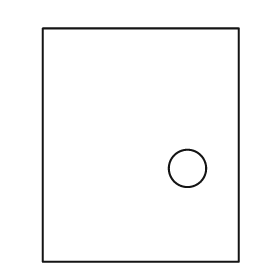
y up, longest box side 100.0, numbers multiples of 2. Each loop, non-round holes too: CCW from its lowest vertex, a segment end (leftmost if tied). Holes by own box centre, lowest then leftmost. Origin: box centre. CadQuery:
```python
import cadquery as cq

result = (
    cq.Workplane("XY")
    .moveTo(-42.0, -50.0)
    .lineTo(42.0, -50.0)
    .lineTo(42.0, 50.0)
    .lineTo(-42.0, 50.0)
    .close()
    .moveTo(20.0, -10.0)
    .circle(8.0)
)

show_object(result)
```